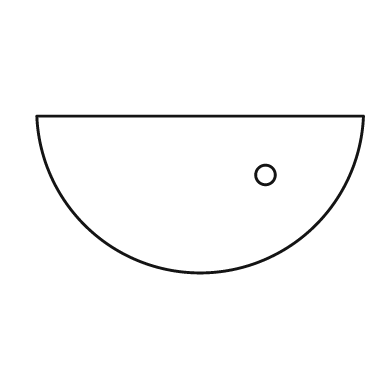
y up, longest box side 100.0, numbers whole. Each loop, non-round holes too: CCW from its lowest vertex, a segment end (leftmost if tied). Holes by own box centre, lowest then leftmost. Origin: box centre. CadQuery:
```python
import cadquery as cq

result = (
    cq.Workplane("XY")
    .moveTo(-50.0, 24.0)
    .threePointArc((0.0, -24.0), (50.0, 24.0))
    .close()
    .moveTo(20.0, 6.0)
    .circle(3.0)
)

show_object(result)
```